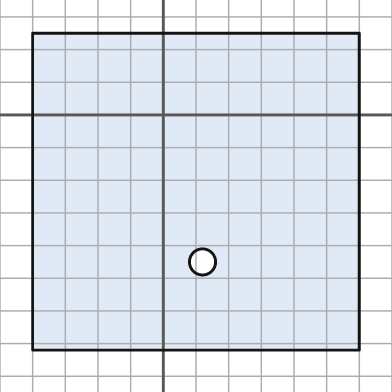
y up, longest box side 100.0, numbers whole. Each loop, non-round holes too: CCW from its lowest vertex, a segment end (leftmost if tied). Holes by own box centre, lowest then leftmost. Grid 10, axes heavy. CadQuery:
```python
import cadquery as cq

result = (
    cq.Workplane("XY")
    .moveTo(-40.0, -72.0)
    .lineTo(60.0, -72.0)
    .lineTo(60.0, 25.0)
    .lineTo(-40.0, 25.0)
    .close()
    .moveTo(12.0, -45.0)
    .circle(4.0)
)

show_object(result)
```